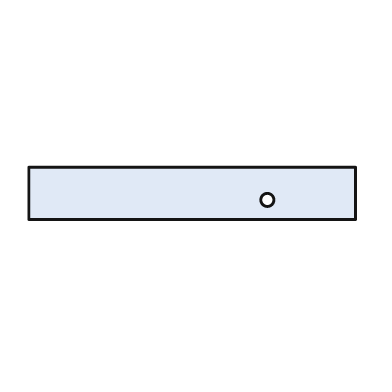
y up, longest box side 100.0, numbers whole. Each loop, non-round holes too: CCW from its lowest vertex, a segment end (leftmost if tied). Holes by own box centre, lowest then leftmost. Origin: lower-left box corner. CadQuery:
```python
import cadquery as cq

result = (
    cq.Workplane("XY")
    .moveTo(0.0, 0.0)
    .lineTo(100.0, 0.0)
    .lineTo(100.0, 16.0)
    .lineTo(0.0, 16.0)
    .close()
    .moveTo(73.0, 6.0)
    .circle(2.0)
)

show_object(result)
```